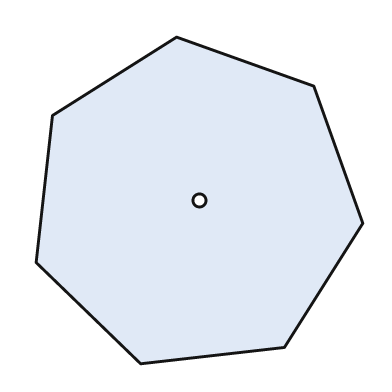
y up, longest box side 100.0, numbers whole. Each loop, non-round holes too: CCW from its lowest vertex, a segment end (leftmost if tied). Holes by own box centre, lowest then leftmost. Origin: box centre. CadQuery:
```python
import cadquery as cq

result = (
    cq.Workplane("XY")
    .moveTo(-18.0, -50.0)
    .lineTo(26.0, -45.0)
    .lineTo(50.0, -7.0)
    .lineTo(35.0, 35.0)
    .lineTo(-7.0, 50.0)
    .lineTo(-45.0, 26.0)
    .lineTo(-50.0, -19.0)
    .close()
    .moveTo(0.0, 0.0)
    .circle(2.0)
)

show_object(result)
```